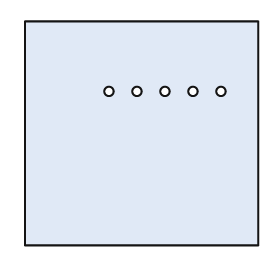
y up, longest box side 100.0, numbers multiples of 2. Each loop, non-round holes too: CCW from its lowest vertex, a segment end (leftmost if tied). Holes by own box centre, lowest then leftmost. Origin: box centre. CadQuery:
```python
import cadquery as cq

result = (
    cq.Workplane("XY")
    .moveTo(-50.0, -48.0)
    .lineTo(50.0, -48.0)
    .lineTo(50.0, 48.0)
    .lineTo(-50.0, 48.0)
    .close()
    .moveTo(-14.0, 18.0)
    .circle(2.0)
    .moveTo(-2.0, 18.0)
    .circle(2.0)
    .moveTo(10.0, 18.0)
    .circle(2.0)
    .moveTo(22.0, 18.0)
    .circle(2.0)
    .moveTo(34.0, 18.0)
    .circle(2.0)
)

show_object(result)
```